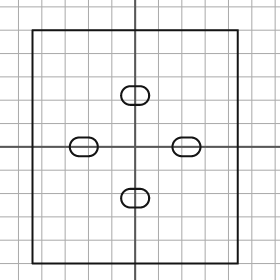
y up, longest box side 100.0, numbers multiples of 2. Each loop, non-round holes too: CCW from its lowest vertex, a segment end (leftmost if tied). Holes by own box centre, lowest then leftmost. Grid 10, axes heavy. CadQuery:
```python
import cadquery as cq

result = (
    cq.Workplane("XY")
    .moveTo(-44.0, -50.0)
    .lineTo(44.0, -50.0)
    .lineTo(44.0, 50.0)
    .lineTo(-44.0, 50.0)
    .close()
    .moveTo(-2.0, -26.0)
    .lineTo(2.0, -26.0)
    .threePointArc((6.0, -22.0), (2.0, -18.0))
    .lineTo(-2.0, -18.0)
    .threePointArc((-6.0, -22.0), (-2.0, -26.0))
    .close()
    .moveTo(-24.0, -4.0)
    .lineTo(-20.0, -4.0)
    .threePointArc((-16.0, 0.0), (-20.0, 4.0))
    .lineTo(-24.0, 4.0)
    .threePointArc((-28.0, 0.0), (-24.0, -4.0))
    .close()
    .moveTo(20.0, -4.0)
    .lineTo(24.0, -4.0)
    .threePointArc((28.0, 0.0), (24.0, 4.0))
    .lineTo(20.0, 4.0)
    .threePointArc((16.0, 0.0), (20.0, -4.0))
    .close()
    .moveTo(-2.0, 18.0)
    .lineTo(2.0, 18.0)
    .threePointArc((6.0, 22.0), (2.0, 26.0))
    .lineTo(-2.0, 26.0)
    .threePointArc((-6.0, 22.0), (-2.0, 18.0))
    .close()
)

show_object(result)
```